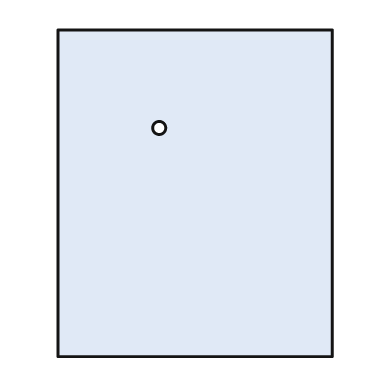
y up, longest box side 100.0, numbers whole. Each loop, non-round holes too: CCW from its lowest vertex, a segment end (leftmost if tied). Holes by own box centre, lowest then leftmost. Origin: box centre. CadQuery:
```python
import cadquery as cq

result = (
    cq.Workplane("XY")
    .moveTo(-42.0, -50.0)
    .lineTo(42.0, -50.0)
    .lineTo(42.0, 50.0)
    .lineTo(-42.0, 50.0)
    .close()
    .moveTo(-11.0, 20.0)
    .circle(2.0)
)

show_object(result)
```